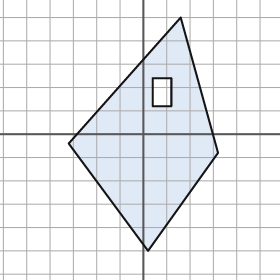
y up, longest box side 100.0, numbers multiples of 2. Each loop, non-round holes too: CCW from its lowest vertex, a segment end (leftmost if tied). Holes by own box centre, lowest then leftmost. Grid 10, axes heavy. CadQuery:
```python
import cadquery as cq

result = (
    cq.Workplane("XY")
    .moveTo(2.0, -50.0)
    .lineTo(32.0, -8.0)
    .lineTo(16.0, 50.0)
    .lineTo(-32.0, -4.0)
    .close()
    .moveTo(4.0, 12.0)
    .lineTo(12.0, 12.0)
    .lineTo(12.0, 24.0)
    .lineTo(4.0, 24.0)
    .close()
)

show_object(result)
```